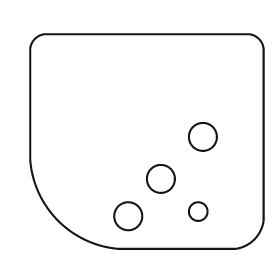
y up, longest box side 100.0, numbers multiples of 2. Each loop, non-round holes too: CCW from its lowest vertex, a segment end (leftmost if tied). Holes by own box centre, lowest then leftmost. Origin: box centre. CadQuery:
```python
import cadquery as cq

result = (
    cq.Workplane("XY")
    .moveTo(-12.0, -46.0)
    .lineTo(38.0, -46.0)
    .threePointArc((46.0, -42.0), (50.0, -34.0))
    .lineTo(50.0, 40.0)
    .threePointArc((48.0, 44.0), (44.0, 46.0))
    .lineTo(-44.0, 46.0)
    .threePointArc((-48.0, 44.0), (-50.0, 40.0))
    .lineTo(-50.0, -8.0)
    .threePointArc((-38.0, -34.0), (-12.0, -46.0))
    .close()
    .moveTo(-8.0, -32.0)
    .circle(6.0)
    .moveTo(22.0, -30.0)
    .circle(4.0)
    .moveTo(6.0, -16.0)
    .circle(6.0)
    .moveTo(24.0, 2.0)
    .circle(6.0)
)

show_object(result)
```